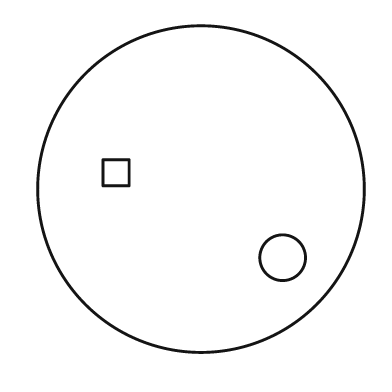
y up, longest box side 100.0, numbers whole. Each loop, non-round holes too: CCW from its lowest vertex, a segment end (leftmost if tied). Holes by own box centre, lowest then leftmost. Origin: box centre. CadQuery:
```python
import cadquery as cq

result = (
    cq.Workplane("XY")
    .moveTo(0.0, 0.0)
    .circle(50.0)
    .moveTo(25.0, -21.0)
    .circle(7.0)
    .moveTo(-30.0, 1.0)
    .lineTo(-22.0, 1.0)
    .lineTo(-22.0, 9.0)
    .lineTo(-30.0, 9.0)
    .close()
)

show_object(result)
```